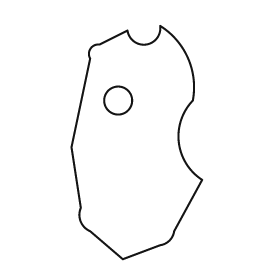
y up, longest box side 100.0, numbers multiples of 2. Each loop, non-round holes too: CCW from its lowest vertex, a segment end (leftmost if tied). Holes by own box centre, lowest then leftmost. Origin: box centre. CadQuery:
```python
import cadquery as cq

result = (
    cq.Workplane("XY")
    .moveTo(-6.0, -50.0)
    .lineTo(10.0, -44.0)
    .threePointArc((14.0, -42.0), (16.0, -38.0))
    .lineTo(28.0, -16.0)
    .threePointArc((18.0, 0.0), (24.0, 18.0))
    .threePointArc((22.0, 36.0), (10.0, 50.0))
    .threePointArc((4.0, 42.0), (-4.0, 48.0))
    .lineTo(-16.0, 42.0)
    .threePointArc((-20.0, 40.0), (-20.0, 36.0))
    .lineTo(-28.0, -2.0)
    .lineTo(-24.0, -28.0)
    .threePointArc((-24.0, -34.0), (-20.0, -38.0))
    .close()
    .moveTo(-8.0, 18.0)
    .circle(6.0)
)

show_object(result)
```